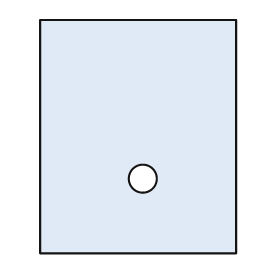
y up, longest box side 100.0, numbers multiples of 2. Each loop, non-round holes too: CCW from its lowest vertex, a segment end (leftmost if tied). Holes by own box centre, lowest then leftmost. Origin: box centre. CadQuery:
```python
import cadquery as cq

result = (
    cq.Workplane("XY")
    .moveTo(-42.0, -50.0)
    .lineTo(42.0, -50.0)
    .lineTo(42.0, 50.0)
    .lineTo(-42.0, 50.0)
    .close()
    .moveTo(2.0, -18.0)
    .circle(6.0)
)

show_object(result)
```